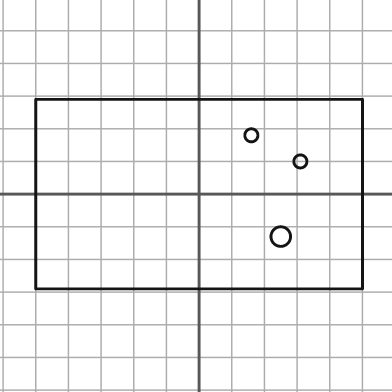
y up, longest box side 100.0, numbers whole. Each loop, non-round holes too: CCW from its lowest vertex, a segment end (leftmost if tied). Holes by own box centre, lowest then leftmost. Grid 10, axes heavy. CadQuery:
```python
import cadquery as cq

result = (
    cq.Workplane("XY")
    .moveTo(-50.0, -29.0)
    .lineTo(50.0, -29.0)
    .lineTo(50.0, 29.0)
    .lineTo(-50.0, 29.0)
    .close()
    .moveTo(25.0, -13.0)
    .circle(3.0)
    .moveTo(31.0, 10.0)
    .circle(2.0)
    .moveTo(16.0, 18.0)
    .circle(2.0)
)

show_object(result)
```